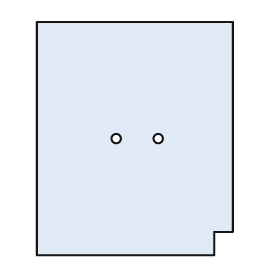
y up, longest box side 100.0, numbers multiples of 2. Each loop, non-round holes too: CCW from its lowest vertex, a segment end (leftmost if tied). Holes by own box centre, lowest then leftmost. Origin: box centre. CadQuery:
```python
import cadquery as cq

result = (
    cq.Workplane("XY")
    .moveTo(-42.0, -50.0)
    .lineTo(34.0, -50.0)
    .lineTo(34.0, -40.0)
    .lineTo(42.0, -40.0)
    .lineTo(42.0, 50.0)
    .lineTo(-42.0, 50.0)
    .close()
    .moveTo(-8.0, 0.0)
    .circle(2.0)
    .moveTo(10.0, 0.0)
    .circle(2.0)
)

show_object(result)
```